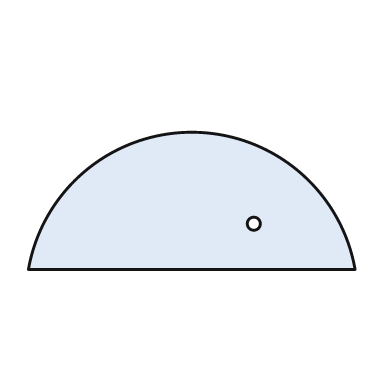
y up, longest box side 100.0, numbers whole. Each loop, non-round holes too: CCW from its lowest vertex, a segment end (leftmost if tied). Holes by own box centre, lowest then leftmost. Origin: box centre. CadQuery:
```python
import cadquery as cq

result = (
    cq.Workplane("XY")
    .moveTo(-50.0, -21.0)
    .lineTo(50.0, -21.0)
    .threePointArc((0.0, 21.0), (-50.0, -21.0))
    .close()
    .moveTo(19.0, -7.0)
    .circle(2.0)
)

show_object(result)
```